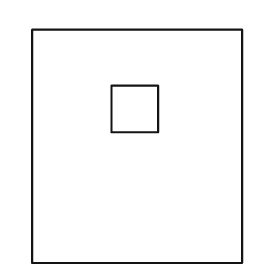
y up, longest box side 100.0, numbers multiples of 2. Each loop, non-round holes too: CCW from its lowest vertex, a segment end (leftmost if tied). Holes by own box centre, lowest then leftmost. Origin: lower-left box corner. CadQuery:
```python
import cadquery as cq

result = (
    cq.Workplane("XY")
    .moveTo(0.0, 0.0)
    .lineTo(90.0, 0.0)
    .lineTo(90.0, 100.0)
    .lineTo(0.0, 100.0)
    .close()
    .moveTo(34.0, 56.0)
    .lineTo(54.0, 56.0)
    .lineTo(54.0, 76.0)
    .lineTo(34.0, 76.0)
    .close()
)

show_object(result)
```